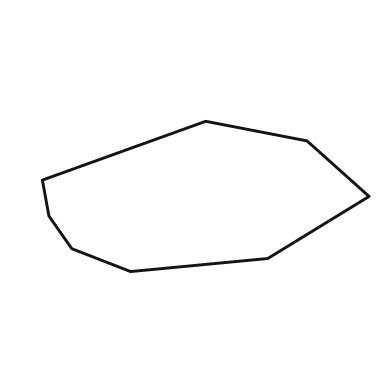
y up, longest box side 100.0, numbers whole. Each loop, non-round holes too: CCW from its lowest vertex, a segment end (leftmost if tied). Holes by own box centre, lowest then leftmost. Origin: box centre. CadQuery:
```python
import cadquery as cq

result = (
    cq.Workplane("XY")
    .moveTo(-23.0, -23.0)
    .lineTo(19.0, -19.0)
    .lineTo(50.0, 0.0)
    .lineTo(31.0, 17.0)
    .lineTo(0.0, 23.0)
    .lineTo(-50.0, 5.0)
    .lineTo(-48.0, -6.0)
    .lineTo(-41.0, -16.0)
    .close()
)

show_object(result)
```